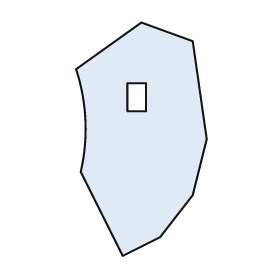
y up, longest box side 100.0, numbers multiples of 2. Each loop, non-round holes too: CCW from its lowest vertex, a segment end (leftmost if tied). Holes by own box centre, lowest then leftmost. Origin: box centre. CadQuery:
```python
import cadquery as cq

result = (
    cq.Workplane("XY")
    .moveTo(-8.0, -50.0)
    .lineTo(8.0, -42.0)
    .lineTo(22.0, -24.0)
    .lineTo(28.0, 0.0)
    .lineTo(22.0, 42.0)
    .lineTo(0.0, 50.0)
    .lineTo(-28.0, 30.0)
    .threePointArc((-24.0, 8.0), (-26.0, -14.0))
    .close()
    .moveTo(-6.0, 12.0)
    .lineTo(2.0, 12.0)
    .lineTo(2.0, 24.0)
    .lineTo(-6.0, 24.0)
    .close()
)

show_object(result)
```